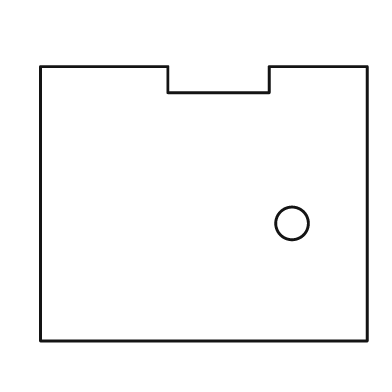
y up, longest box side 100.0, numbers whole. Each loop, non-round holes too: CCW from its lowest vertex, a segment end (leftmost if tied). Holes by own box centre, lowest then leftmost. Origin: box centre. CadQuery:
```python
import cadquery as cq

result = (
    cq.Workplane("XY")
    .moveTo(-50.0, -42.0)
    .lineTo(50.0, -42.0)
    .lineTo(50.0, 42.0)
    .lineTo(20.0, 42.0)
    .lineTo(20.0, 34.0)
    .lineTo(-11.0, 34.0)
    .lineTo(-11.0, 42.0)
    .lineTo(-50.0, 42.0)
    .close()
    .moveTo(27.0, -6.0)
    .circle(5.0)
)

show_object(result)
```